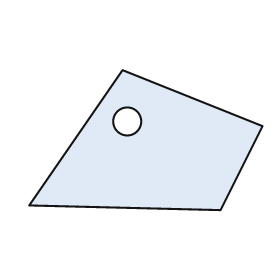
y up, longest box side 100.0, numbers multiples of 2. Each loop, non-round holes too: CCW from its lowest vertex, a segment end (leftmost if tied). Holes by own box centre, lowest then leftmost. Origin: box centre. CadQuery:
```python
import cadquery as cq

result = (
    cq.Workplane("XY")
    .moveTo(32.0, -30.0)
    .lineTo(50.0, 6.0)
    .lineTo(-10.0, 30.0)
    .lineTo(-50.0, -28.0)
    .close()
    .moveTo(-8.0, 8.0)
    .circle(6.0)
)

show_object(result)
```